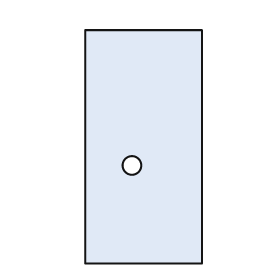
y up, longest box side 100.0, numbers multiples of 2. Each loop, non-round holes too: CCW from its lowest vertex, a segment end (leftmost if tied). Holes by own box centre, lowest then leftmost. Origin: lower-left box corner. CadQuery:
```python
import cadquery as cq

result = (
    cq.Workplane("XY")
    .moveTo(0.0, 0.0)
    .lineTo(50.0, 0.0)
    .lineTo(50.0, 100.0)
    .lineTo(0.0, 100.0)
    .close()
    .moveTo(20.0, 42.0)
    .circle(4.0)
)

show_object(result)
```